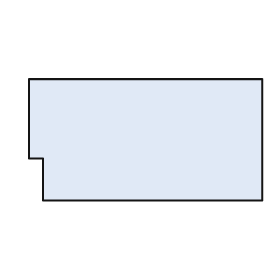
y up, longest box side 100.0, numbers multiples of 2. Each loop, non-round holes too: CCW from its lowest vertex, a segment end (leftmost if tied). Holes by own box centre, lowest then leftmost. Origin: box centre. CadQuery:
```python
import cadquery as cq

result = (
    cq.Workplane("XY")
    .moveTo(-44.0, -26.0)
    .lineTo(50.0, -26.0)
    .lineTo(50.0, 26.0)
    .lineTo(-50.0, 26.0)
    .lineTo(-50.0, -8.0)
    .lineTo(-44.0, -8.0)
    .close()
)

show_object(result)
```